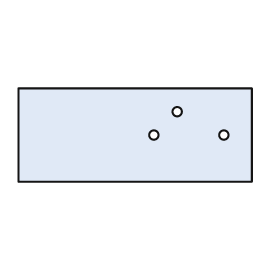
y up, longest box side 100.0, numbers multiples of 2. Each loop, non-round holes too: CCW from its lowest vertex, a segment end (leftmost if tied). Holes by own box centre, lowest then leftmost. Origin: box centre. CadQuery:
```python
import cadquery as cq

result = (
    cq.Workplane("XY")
    .moveTo(-50.0, -20.0)
    .lineTo(50.0, -20.0)
    .lineTo(50.0, 20.0)
    .lineTo(-50.0, 20.0)
    .close()
    .moveTo(8.0, 0.0)
    .circle(2.0)
    .moveTo(38.0, 0.0)
    .circle(2.0)
    .moveTo(18.0, 10.0)
    .circle(2.0)
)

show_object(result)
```